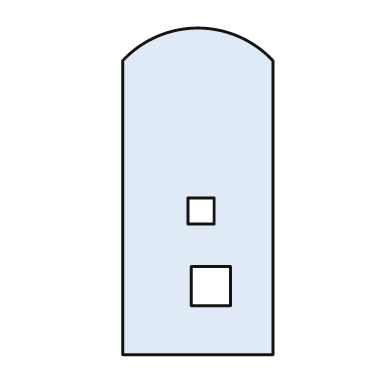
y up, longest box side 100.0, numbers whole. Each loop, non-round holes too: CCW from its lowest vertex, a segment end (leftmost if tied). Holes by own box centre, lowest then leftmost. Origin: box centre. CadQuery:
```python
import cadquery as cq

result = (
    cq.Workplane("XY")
    .moveTo(-23.0, -50.0)
    .lineTo(23.0, -50.0)
    .lineTo(23.0, 40.0)
    .threePointArc((0.0, 50.0), (-23.0, 40.0))
    .close()
    .moveTo(-2.0, -35.0)
    .lineTo(10.0, -35.0)
    .lineTo(10.0, -23.0)
    .lineTo(-2.0, -23.0)
    .close()
    .moveTo(-3.0, -10.0)
    .lineTo(5.0, -10.0)
    .lineTo(5.0, -2.0)
    .lineTo(-3.0, -2.0)
    .close()
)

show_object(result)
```